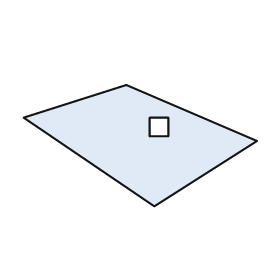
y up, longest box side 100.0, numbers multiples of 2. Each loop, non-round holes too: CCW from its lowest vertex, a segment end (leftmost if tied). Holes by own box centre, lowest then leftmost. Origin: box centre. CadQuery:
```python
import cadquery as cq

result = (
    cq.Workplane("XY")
    .moveTo(6.0, -26.0)
    .lineTo(50.0, 2.0)
    .lineTo(-6.0, 26.0)
    .lineTo(-50.0, 12.0)
    .close()
    .moveTo(4.0, 4.0)
    .lineTo(12.0, 4.0)
    .lineTo(12.0, 12.0)
    .lineTo(4.0, 12.0)
    .close()
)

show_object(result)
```